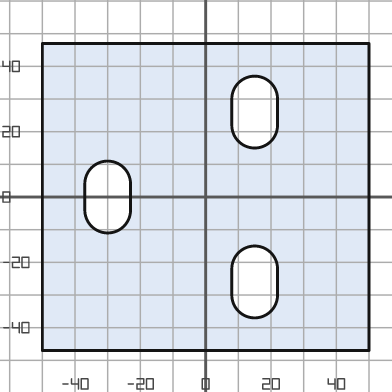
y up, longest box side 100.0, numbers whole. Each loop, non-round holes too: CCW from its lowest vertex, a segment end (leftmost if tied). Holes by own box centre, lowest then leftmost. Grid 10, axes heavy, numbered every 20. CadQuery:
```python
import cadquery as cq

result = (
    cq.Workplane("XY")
    .moveTo(-50.0, -47.0)
    .lineTo(50.0, -47.0)
    .lineTo(50.0, 47.0)
    .lineTo(-50.0, 47.0)
    .close()
    .moveTo(8.0, -30.0)
    .threePointArc((15.0, -37.0), (22.0, -30.0))
    .lineTo(22.0, -22.0)
    .threePointArc((15.0, -15.0), (8.0, -22.0))
    .close()
    .moveTo(-37.0, -4.0)
    .threePointArc((-30.0, -11.0), (-23.0, -4.0))
    .lineTo(-23.0, 4.0)
    .threePointArc((-30.0, 11.0), (-37.0, 4.0))
    .close()
    .moveTo(8.0, 22.0)
    .threePointArc((15.0, 15.0), (22.0, 22.0))
    .lineTo(22.0, 30.0)
    .threePointArc((15.0, 37.0), (8.0, 30.0))
    .close()
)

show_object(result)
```